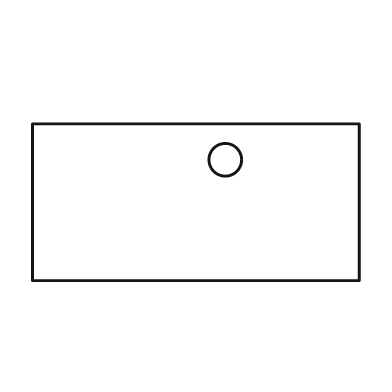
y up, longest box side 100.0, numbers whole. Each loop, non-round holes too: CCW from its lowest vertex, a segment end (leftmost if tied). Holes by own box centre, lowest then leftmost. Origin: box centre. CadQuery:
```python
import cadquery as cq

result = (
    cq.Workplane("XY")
    .moveTo(-50.0, -24.0)
    .lineTo(50.0, -24.0)
    .lineTo(50.0, 24.0)
    .lineTo(-50.0, 24.0)
    .close()
    .moveTo(9.0, 13.0)
    .circle(5.0)
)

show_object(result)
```